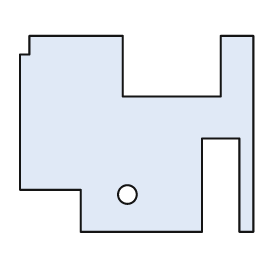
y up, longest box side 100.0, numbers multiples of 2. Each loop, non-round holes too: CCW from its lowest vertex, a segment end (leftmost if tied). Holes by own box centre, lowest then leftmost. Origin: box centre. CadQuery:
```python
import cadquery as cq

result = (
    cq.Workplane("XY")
    .moveTo(-24.0, -42.0)
    .lineTo(28.0, -42.0)
    .lineTo(28.0, -2.0)
    .lineTo(44.0, -2.0)
    .lineTo(44.0, -42.0)
    .lineTo(50.0, -42.0)
    .lineTo(50.0, 42.0)
    .lineTo(36.0, 42.0)
    .lineTo(36.0, 16.0)
    .lineTo(-6.0, 16.0)
    .lineTo(-6.0, 42.0)
    .lineTo(-46.0, 42.0)
    .lineTo(-46.0, 34.0)
    .lineTo(-50.0, 34.0)
    .lineTo(-50.0, -24.0)
    .lineTo(-24.0, -24.0)
    .close()
    .moveTo(-4.0, -26.0)
    .circle(4.0)
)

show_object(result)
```